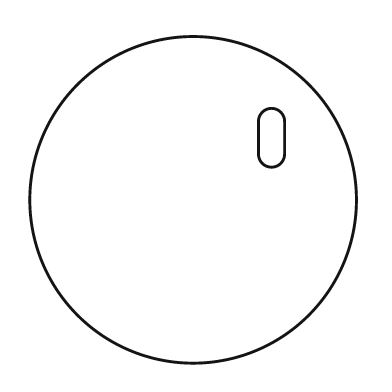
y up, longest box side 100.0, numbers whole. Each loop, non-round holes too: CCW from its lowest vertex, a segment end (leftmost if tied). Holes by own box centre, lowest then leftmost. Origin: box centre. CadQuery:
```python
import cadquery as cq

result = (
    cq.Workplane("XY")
    .moveTo(0.0, 0.0)
    .circle(50.0)
    .moveTo(20.0, 14.0)
    .threePointArc((24.0, 10.0), (28.0, 14.0))
    .lineTo(28.0, 24.0)
    .threePointArc((24.0, 28.0), (20.0, 24.0))
    .close()
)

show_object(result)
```